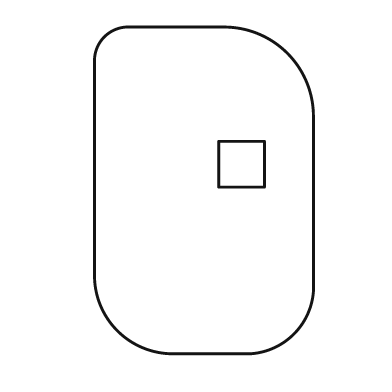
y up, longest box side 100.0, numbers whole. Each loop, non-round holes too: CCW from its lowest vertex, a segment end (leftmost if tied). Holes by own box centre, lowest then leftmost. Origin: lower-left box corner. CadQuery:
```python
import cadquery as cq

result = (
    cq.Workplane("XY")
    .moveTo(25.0, 0.0)
    .lineTo(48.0, 0.0)
    .threePointArc((61.0, 6.0), (67.0, 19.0))
    .lineTo(67.0, 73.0)
    .threePointArc((59.0, 92.0), (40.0, 100.0))
    .lineTo(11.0, 100.0)
    .threePointArc((3.0, 97.0), (0.0, 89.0))
    .lineTo(0.0, 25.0)
    .threePointArc((7.0, 7.0), (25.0, 0.0))
    .close()
    .moveTo(38.0, 51.0)
    .lineTo(52.0, 51.0)
    .lineTo(52.0, 65.0)
    .lineTo(38.0, 65.0)
    .close()
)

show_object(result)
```